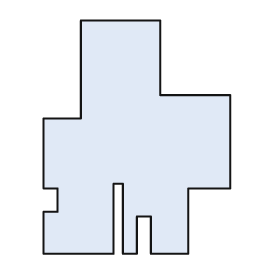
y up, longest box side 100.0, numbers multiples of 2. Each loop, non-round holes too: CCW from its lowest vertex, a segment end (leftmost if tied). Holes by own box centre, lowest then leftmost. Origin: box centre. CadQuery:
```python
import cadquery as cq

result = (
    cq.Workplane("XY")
    .moveTo(-40.0, -50.0)
    .lineTo(-10.0, -50.0)
    .lineTo(-10.0, -20.0)
    .lineTo(-6.0, -20.0)
    .lineTo(-6.0, -50.0)
    .lineTo(0.0, -50.0)
    .lineTo(0.0, -34.0)
    .lineTo(6.0, -34.0)
    .lineTo(6.0, -50.0)
    .lineTo(22.0, -50.0)
    .lineTo(22.0, -22.0)
    .lineTo(40.0, -22.0)
    .lineTo(40.0, 18.0)
    .lineTo(10.0, 18.0)
    .lineTo(10.0, 50.0)
    .lineTo(-24.0, 50.0)
    .lineTo(-24.0, 8.0)
    .lineTo(-40.0, 8.0)
    .lineTo(-40.0, -22.0)
    .lineTo(-34.0, -22.0)
    .lineTo(-34.0, -32.0)
    .lineTo(-40.0, -32.0)
    .close()
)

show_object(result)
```